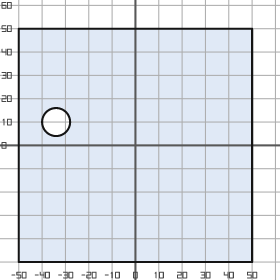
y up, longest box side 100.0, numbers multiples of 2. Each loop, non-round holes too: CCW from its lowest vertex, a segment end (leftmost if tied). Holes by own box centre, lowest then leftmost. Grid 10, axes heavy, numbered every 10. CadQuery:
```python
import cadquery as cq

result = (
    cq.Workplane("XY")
    .moveTo(-50.0, -50.0)
    .lineTo(50.0, -50.0)
    .lineTo(50.0, 50.0)
    .lineTo(-50.0, 50.0)
    .close()
    .moveTo(-34.0, 10.0)
    .circle(6.0)
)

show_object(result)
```